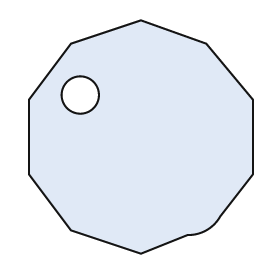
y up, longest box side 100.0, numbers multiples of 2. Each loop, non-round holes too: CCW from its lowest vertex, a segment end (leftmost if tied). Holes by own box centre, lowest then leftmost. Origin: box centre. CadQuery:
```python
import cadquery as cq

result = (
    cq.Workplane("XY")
    .moveTo(0.0, -50.0)
    .lineTo(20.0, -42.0)
    .threePointArc((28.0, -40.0), (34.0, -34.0))
    .lineTo(48.0, -16.0)
    .lineTo(48.0, 16.0)
    .lineTo(28.0, 40.0)
    .lineTo(0.0, 50.0)
    .lineTo(-30.0, 40.0)
    .lineTo(-48.0, 16.0)
    .lineTo(-48.0, -16.0)
    .lineTo(-30.0, -40.0)
    .close()
    .moveTo(-26.0, 18.0)
    .circle(8.0)
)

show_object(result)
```